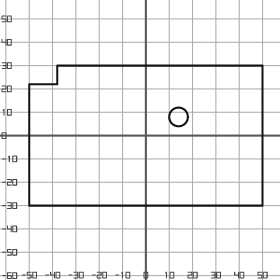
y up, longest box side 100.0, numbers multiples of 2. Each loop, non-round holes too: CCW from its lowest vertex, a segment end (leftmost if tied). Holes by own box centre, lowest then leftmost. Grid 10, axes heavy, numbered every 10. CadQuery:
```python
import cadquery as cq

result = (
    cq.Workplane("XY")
    .moveTo(-50.0, -30.0)
    .lineTo(50.0, -30.0)
    .lineTo(50.0, 30.0)
    .lineTo(-38.0, 30.0)
    .lineTo(-38.0, 22.0)
    .lineTo(-50.0, 22.0)
    .close()
    .moveTo(14.0, 8.0)
    .circle(4.0)
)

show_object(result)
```